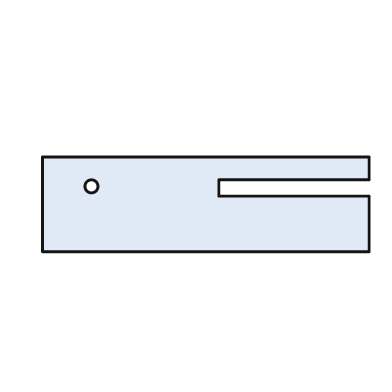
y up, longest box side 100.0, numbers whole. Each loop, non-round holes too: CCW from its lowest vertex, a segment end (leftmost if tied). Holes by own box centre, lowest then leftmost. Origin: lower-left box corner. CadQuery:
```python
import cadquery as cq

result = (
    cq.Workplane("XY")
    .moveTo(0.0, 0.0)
    .lineTo(100.0, 0.0)
    .lineTo(100.0, 17.0)
    .lineTo(54.0, 17.0)
    .lineTo(54.0, 22.0)
    .lineTo(100.0, 22.0)
    .lineTo(100.0, 29.0)
    .lineTo(0.0, 29.0)
    .close()
    .moveTo(15.0, 20.0)
    .circle(2.0)
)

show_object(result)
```